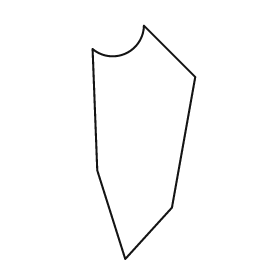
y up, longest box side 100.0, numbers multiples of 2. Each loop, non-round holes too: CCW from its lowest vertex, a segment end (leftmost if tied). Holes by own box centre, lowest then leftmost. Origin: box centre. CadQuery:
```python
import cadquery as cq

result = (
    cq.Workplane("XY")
    .moveTo(-8.0, -50.0)
    .lineTo(12.0, -28.0)
    .lineTo(22.0, 28.0)
    .lineTo(0.0, 50.0)
    .threePointArc((-8.0, 38.0), (-22.0, 40.0))
    .lineTo(-20.0, -12.0)
    .close()
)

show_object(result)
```